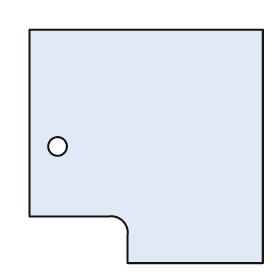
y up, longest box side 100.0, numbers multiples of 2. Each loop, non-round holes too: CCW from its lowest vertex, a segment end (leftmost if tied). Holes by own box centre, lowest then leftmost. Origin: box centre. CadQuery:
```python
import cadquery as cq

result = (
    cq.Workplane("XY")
    .moveTo(-8.0, -50.0)
    .lineTo(50.0, -50.0)
    .lineTo(50.0, 50.0)
    .lineTo(-50.0, 50.0)
    .lineTo(-50.0, -30.0)
    .lineTo(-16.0, -30.0)
    .threePointArc((-10.0, -32.0), (-8.0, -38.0))
    .close()
    .moveTo(-38.0, 0.0)
    .circle(4.0)
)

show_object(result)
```